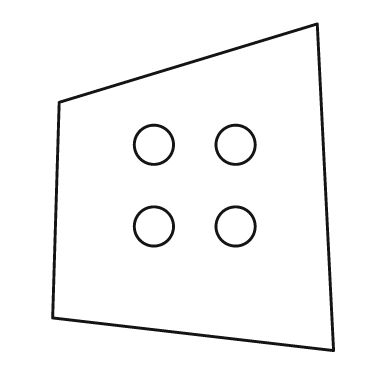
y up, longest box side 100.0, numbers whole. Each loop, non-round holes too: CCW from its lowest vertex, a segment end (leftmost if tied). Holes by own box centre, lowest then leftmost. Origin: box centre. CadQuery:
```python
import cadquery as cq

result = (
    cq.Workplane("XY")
    .moveTo(43.0, -50.0)
    .lineTo(38.0, 50.0)
    .lineTo(-41.0, 26.0)
    .lineTo(-43.0, -40.0)
    .close()
    .moveTo(-12.0, -12.0)
    .circle(6.0)
    .moveTo(13.0, -12.0)
    .circle(6.0)
    .moveTo(-12.0, 13.0)
    .circle(6.0)
    .moveTo(13.0, 13.0)
    .circle(6.0)
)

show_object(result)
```